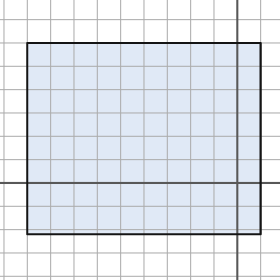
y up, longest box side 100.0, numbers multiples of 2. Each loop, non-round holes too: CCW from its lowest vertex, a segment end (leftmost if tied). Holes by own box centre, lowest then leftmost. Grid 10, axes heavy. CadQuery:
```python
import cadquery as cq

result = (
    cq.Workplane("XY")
    .moveTo(-90.0, -22.0)
    .lineTo(10.0, -22.0)
    .lineTo(10.0, 60.0)
    .lineTo(-90.0, 60.0)
    .close()
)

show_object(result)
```